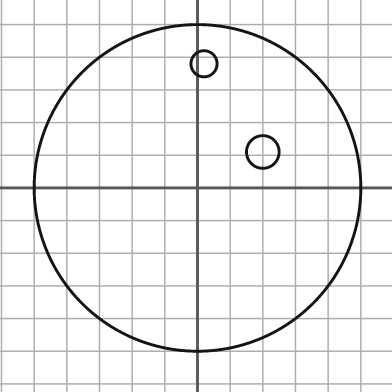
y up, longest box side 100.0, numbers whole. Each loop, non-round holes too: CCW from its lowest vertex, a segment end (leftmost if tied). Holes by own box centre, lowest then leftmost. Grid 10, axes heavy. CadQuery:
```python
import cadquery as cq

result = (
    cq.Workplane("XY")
    .moveTo(0.0, 0.0)
    .circle(50.0)
    .moveTo(20.0, 11.0)
    .circle(5.0)
    .moveTo(2.0, 38.0)
    .circle(4.0)
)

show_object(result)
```